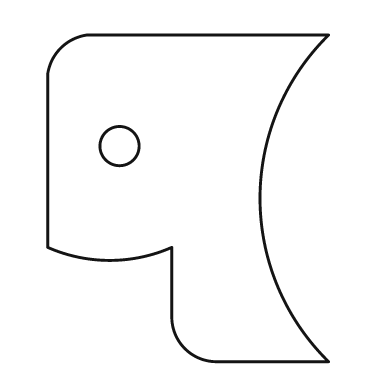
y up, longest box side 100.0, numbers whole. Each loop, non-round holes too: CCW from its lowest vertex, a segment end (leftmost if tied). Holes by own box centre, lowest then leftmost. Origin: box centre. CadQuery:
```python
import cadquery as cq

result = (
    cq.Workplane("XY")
    .moveTo(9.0, -50.0)
    .lineTo(43.0, -50.0)
    .threePointArc((22.0, 0.0), (43.0, 50.0))
    .lineTo(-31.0, 50.0)
    .threePointArc((-39.0, 46.0), (-43.0, 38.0))
    .lineTo(-43.0, -15.0)
    .threePointArc((-24.0, -19.0), (-5.0, -15.0))
    .lineTo(-5.0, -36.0)
    .threePointArc((-1.0, -46.0), (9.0, -50.0))
    .close()
    .moveTo(-21.0, 16.0)
    .circle(6.0)
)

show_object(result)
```